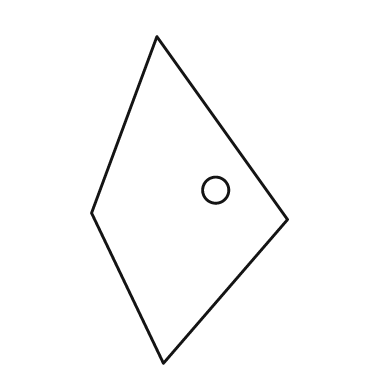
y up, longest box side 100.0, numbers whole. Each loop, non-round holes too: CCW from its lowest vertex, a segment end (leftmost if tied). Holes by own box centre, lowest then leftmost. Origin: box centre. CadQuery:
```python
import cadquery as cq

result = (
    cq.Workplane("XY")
    .moveTo(-8.0, -50.0)
    .lineTo(30.0, -6.0)
    .lineTo(-10.0, 50.0)
    .lineTo(-30.0, -4.0)
    .close()
    .moveTo(8.0, 3.0)
    .circle(4.0)
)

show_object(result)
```